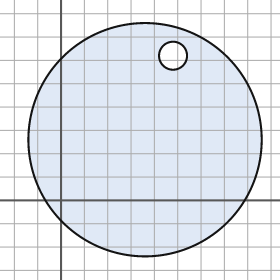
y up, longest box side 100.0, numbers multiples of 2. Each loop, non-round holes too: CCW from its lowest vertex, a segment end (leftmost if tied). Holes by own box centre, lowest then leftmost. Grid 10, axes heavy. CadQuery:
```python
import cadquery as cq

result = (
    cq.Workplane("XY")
    .moveTo(36.0, 26.0)
    .circle(50.0)
    .moveTo(48.0, 62.0)
    .circle(6.0)
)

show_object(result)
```